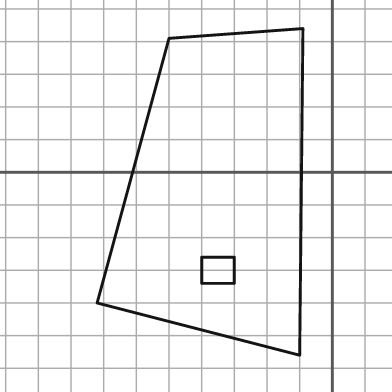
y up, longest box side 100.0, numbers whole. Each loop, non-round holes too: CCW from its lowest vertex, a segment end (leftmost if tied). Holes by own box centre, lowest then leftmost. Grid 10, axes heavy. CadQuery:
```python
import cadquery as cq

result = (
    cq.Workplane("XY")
    .moveTo(-10.0, -56.0)
    .lineTo(-9.0, 44.0)
    .lineTo(-50.0, 41.0)
    .lineTo(-72.0, -40.0)
    .close()
    .moveTo(-40.0, -34.0)
    .lineTo(-30.0, -34.0)
    .lineTo(-30.0, -26.0)
    .lineTo(-40.0, -26.0)
    .close()
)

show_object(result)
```